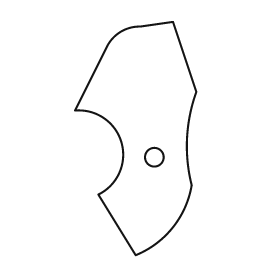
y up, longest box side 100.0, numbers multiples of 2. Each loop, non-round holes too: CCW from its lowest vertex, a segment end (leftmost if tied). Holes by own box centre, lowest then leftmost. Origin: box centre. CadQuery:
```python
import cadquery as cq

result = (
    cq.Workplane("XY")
    .moveTo(0.0, -50.0)
    .threePointArc((16.0, -38.0), (24.0, -20.0))
    .threePointArc((22.0, 0.0), (26.0, 20.0))
    .lineTo(16.0, 50.0)
    .lineTo(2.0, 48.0)
    .threePointArc((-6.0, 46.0), (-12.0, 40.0))
    .lineTo(-26.0, 12.0)
    .threePointArc((-6.0, -2.0), (-16.0, -24.0))
    .close()
    .moveTo(8.0, -8.0)
    .circle(4.0)
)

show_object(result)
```